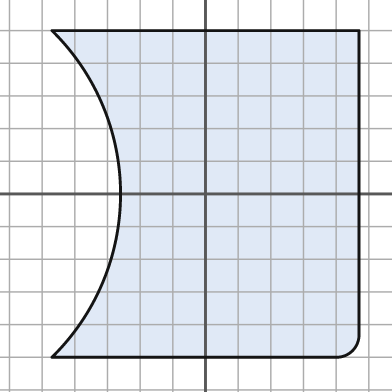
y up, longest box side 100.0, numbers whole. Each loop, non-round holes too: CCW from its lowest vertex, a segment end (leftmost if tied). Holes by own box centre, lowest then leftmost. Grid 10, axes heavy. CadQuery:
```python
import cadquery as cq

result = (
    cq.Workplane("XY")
    .moveTo(-47.0, -50.0)
    .lineTo(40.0, -50.0)
    .threePointArc((45.0, -48.0), (47.0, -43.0))
    .lineTo(47.0, 50.0)
    .lineTo(-47.0, 50.0)
    .threePointArc((-26.0, 0.0), (-47.0, -50.0))
    .close()
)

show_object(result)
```